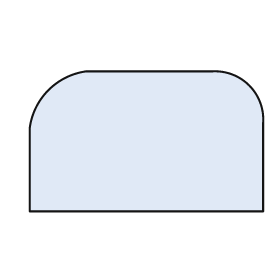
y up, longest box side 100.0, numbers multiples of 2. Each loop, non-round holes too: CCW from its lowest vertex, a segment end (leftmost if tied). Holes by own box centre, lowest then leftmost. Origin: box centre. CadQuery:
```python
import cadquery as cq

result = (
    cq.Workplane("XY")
    .moveTo(-50.0, -30.0)
    .lineTo(50.0, -30.0)
    .lineTo(50.0, 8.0)
    .threePointArc((44.0, 24.0), (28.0, 30.0))
    .lineTo(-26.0, 30.0)
    .threePointArc((-42.0, 22.0), (-50.0, 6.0))
    .close()
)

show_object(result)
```